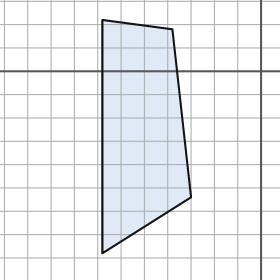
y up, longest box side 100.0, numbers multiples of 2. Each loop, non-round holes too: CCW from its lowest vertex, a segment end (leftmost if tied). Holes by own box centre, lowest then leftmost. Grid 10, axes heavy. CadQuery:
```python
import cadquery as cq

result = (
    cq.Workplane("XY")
    .moveTo(-68.0, -78.0)
    .lineTo(-30.0, -54.0)
    .lineTo(-38.0, 18.0)
    .lineTo(-68.0, 22.0)
    .close()
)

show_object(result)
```